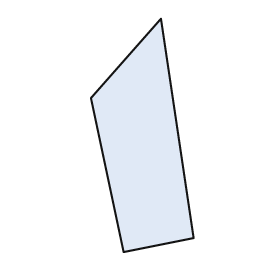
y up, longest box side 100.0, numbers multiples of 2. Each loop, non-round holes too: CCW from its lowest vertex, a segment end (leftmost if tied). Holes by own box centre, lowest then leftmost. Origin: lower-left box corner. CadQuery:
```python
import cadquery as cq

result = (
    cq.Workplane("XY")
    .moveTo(14.0, 0.0)
    .lineTo(44.0, 6.0)
    .lineTo(30.0, 100.0)
    .lineTo(0.0, 66.0)
    .close()
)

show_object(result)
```